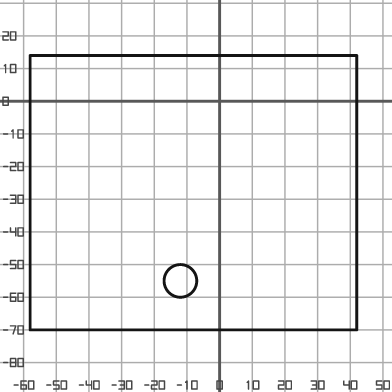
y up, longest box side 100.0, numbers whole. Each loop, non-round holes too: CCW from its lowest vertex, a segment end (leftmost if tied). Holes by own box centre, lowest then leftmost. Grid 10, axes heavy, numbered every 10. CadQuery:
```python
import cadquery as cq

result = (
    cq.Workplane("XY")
    .moveTo(-58.0, -70.0)
    .lineTo(42.0, -70.0)
    .lineTo(42.0, 14.0)
    .lineTo(-58.0, 14.0)
    .close()
    .moveTo(-12.0, -55.0)
    .circle(5.0)
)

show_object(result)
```